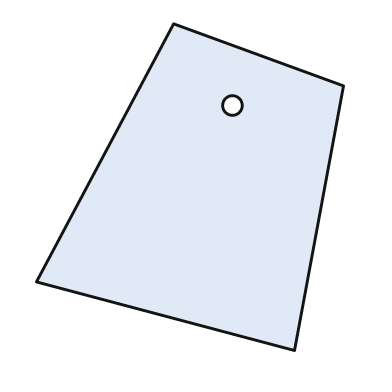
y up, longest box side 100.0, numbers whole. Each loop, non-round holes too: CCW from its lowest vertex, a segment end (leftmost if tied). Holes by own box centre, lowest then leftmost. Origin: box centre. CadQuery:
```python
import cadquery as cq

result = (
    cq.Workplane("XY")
    .moveTo(32.0, -50.0)
    .lineTo(47.0, 31.0)
    .lineTo(-5.0, 50.0)
    .lineTo(-47.0, -29.0)
    .close()
    .moveTo(13.0, 25.0)
    .circle(3.0)
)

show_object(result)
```